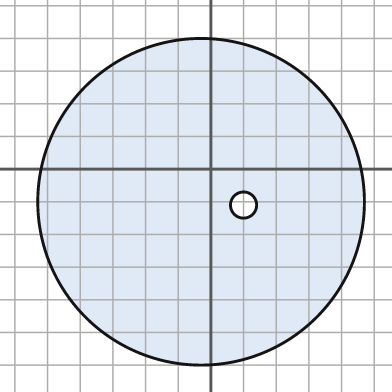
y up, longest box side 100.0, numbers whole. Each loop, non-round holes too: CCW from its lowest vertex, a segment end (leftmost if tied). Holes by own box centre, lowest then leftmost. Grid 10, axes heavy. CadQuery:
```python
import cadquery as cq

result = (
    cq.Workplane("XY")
    .moveTo(-3.0, -10.0)
    .circle(50.0)
    .moveTo(10.0, -11.0)
    .circle(4.0)
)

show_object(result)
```